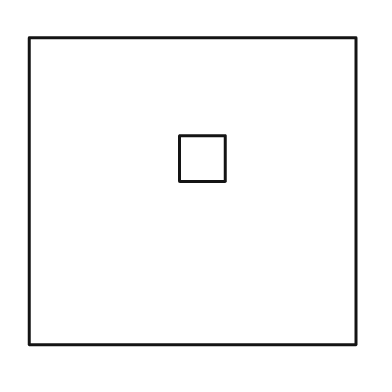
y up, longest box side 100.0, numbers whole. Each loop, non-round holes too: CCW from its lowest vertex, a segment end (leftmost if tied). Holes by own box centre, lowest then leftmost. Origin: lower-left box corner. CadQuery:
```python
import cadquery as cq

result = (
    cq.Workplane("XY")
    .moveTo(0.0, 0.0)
    .lineTo(100.0, 0.0)
    .lineTo(100.0, 94.0)
    .lineTo(0.0, 94.0)
    .close()
    .moveTo(46.0, 50.0)
    .lineTo(60.0, 50.0)
    .lineTo(60.0, 64.0)
    .lineTo(46.0, 64.0)
    .close()
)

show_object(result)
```